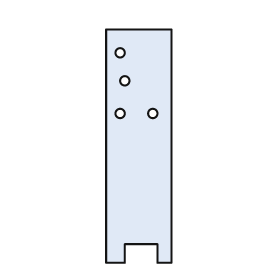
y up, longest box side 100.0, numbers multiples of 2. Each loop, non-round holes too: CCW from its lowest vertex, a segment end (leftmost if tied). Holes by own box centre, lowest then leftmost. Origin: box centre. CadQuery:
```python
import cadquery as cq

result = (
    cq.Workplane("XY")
    .moveTo(-14.0, -50.0)
    .lineTo(-6.0, -50.0)
    .lineTo(-6.0, -42.0)
    .lineTo(8.0, -42.0)
    .lineTo(8.0, -50.0)
    .lineTo(14.0, -50.0)
    .lineTo(14.0, 50.0)
    .lineTo(-14.0, 50.0)
    .close()
    .moveTo(-8.0, 14.0)
    .circle(2.0)
    .moveTo(6.0, 14.0)
    .circle(2.0)
    .moveTo(-6.0, 28.0)
    .circle(2.0)
    .moveTo(-8.0, 40.0)
    .circle(2.0)
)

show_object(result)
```